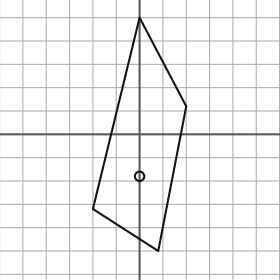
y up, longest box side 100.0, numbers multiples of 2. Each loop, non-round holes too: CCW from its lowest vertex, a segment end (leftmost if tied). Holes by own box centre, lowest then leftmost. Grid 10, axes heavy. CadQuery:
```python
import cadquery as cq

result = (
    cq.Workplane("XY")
    .moveTo(8.0, -50.0)
    .lineTo(20.0, 12.0)
    .lineTo(0.0, 50.0)
    .lineTo(-20.0, -32.0)
    .close()
    .moveTo(0.0, -18.0)
    .circle(2.0)
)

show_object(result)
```